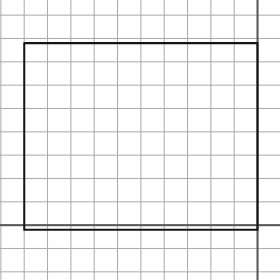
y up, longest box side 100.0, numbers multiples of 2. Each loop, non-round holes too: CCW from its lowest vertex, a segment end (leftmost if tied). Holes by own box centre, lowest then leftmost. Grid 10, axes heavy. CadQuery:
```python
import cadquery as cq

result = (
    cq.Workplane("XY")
    .moveTo(-100.0, -2.0)
    .lineTo(0.0, -2.0)
    .lineTo(0.0, 78.0)
    .lineTo(-100.0, 78.0)
    .close()
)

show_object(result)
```